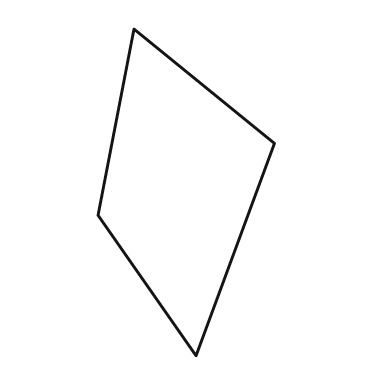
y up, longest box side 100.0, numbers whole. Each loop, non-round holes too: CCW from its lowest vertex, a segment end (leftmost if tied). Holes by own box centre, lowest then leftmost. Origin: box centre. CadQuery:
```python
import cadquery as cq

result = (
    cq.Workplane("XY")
    .moveTo(3.0, -50.0)
    .lineTo(27.0, 15.0)
    .lineTo(-16.0, 50.0)
    .lineTo(-27.0, -7.0)
    .close()
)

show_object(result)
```